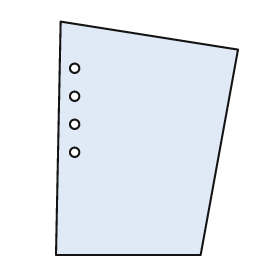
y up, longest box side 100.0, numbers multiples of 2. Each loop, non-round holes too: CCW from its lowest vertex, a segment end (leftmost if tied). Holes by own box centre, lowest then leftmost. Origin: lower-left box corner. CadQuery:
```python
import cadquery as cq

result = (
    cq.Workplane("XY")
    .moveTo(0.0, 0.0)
    .lineTo(62.0, 0.0)
    .lineTo(78.0, 88.0)
    .lineTo(2.0, 100.0)
    .close()
    .moveTo(8.0, 44.0)
    .circle(2.0)
    .moveTo(8.0, 56.0)
    .circle(2.0)
    .moveTo(8.0, 68.0)
    .circle(2.0)
    .moveTo(8.0, 80.0)
    .circle(2.0)
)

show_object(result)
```